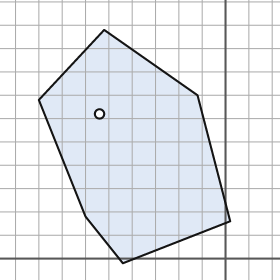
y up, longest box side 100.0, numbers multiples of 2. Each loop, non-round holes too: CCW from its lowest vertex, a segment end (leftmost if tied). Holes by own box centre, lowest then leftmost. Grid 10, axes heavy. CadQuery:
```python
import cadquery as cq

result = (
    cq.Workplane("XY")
    .moveTo(-44.0, -2.0)
    .lineTo(2.0, 16.0)
    .lineTo(-12.0, 70.0)
    .lineTo(-52.0, 98.0)
    .lineTo(-80.0, 68.0)
    .lineTo(-60.0, 18.0)
    .close()
    .moveTo(-54.0, 62.0)
    .circle(2.0)
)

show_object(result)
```